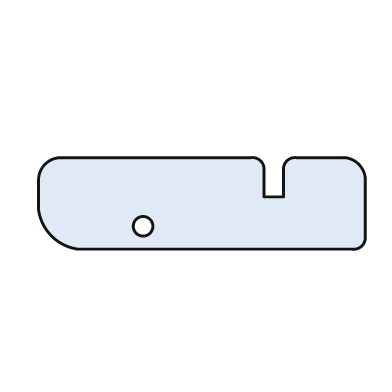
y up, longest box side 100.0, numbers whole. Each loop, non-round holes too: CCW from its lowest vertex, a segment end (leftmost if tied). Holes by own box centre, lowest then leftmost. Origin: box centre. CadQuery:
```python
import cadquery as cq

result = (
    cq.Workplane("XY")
    .moveTo(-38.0, -14.0)
    .lineTo(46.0, -14.0)
    .threePointArc((49.0, -13.0), (50.0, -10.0))
    .lineTo(50.0, 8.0)
    .threePointArc((48.0, 12.0), (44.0, 14.0))
    .lineTo(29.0, 14.0)
    .threePointArc((26.0, 13.0), (25.0, 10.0))
    .lineTo(25.0, 2.0)
    .lineTo(19.0, 2.0)
    .lineTo(19.0, 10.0)
    .threePointArc((18.0, 13.0), (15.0, 14.0))
    .lineTo(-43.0, 14.0)
    .threePointArc((-48.0, 12.0), (-50.0, 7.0))
    .lineTo(-50.0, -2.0)
    .threePointArc((-46.0, -10.0), (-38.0, -14.0))
    .close()
    .moveTo(-18.0, -7.0)
    .circle(3.0)
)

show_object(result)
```